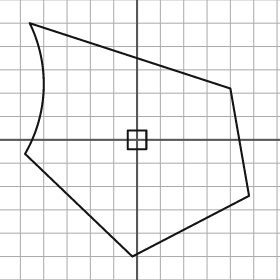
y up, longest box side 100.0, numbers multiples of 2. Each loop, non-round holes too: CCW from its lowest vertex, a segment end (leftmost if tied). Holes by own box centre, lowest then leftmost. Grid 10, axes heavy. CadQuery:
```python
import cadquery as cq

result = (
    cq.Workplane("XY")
    .moveTo(-2.0, -50.0)
    .lineTo(48.0, -24.0)
    .lineTo(40.0, 22.0)
    .lineTo(-46.0, 50.0)
    .threePointArc((-40.0, 22.0), (-48.0, -6.0))
    .close()
    .moveTo(-4.0, -4.0)
    .lineTo(4.0, -4.0)
    .lineTo(4.0, 4.0)
    .lineTo(-4.0, 4.0)
    .close()
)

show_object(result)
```